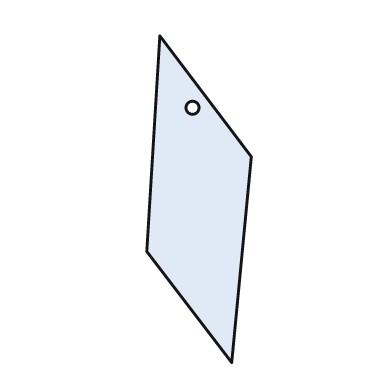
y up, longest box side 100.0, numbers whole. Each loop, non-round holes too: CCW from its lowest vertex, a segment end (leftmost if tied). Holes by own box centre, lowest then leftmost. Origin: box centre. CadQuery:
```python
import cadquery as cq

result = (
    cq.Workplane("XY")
    .moveTo(10.0, -50.0)
    .lineTo(16.0, 13.0)
    .lineTo(-12.0, 50.0)
    .lineTo(-16.0, -16.0)
    .close()
    .moveTo(-2.0, 28.0)
    .circle(2.0)
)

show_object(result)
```